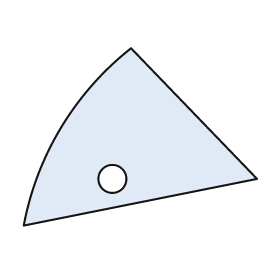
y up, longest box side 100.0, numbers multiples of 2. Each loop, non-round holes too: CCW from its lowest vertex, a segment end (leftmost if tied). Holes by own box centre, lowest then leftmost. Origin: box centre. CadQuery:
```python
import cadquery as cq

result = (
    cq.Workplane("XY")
    .moveTo(-50.0, -38.0)
    .lineTo(50.0, -18.0)
    .lineTo(-4.0, 38.0)
    .threePointArc((-34.0, 4.0), (-50.0, -38.0))
    .close()
    .moveTo(-12.0, -18.0)
    .circle(6.0)
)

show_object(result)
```